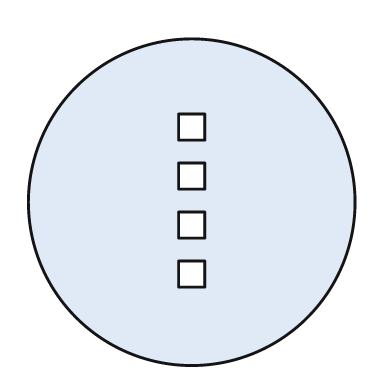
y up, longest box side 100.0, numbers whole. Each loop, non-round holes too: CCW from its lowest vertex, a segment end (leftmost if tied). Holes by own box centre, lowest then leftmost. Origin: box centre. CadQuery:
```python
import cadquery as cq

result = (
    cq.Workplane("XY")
    .moveTo(0.0, 0.0)
    .circle(50.0)
    .moveTo(-4.0, -26.0)
    .lineTo(4.0, -26.0)
    .lineTo(4.0, -18.0)
    .lineTo(-4.0, -18.0)
    .close()
    .moveTo(-4.0, -11.0)
    .lineTo(4.0, -11.0)
    .lineTo(4.0, -3.0)
    .lineTo(-4.0, -3.0)
    .close()
    .moveTo(-4.0, 4.0)
    .lineTo(4.0, 4.0)
    .lineTo(4.0, 12.0)
    .lineTo(-4.0, 12.0)
    .close()
    .moveTo(-4.0, 19.0)
    .lineTo(4.0, 19.0)
    .lineTo(4.0, 27.0)
    .lineTo(-4.0, 27.0)
    .close()
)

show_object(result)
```